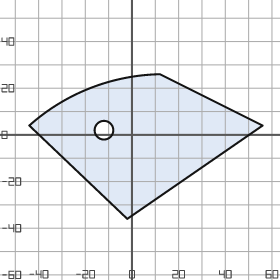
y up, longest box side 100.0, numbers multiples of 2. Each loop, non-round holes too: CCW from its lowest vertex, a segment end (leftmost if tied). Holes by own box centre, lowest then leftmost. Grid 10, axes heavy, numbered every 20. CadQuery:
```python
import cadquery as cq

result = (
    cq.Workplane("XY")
    .moveTo(-2.0, -36.0)
    .lineTo(56.0, 4.0)
    .lineTo(12.0, 26.0)
    .threePointArc((-18.0, 20.0), (-44.0, 4.0))
    .close()
    .moveTo(-12.0, 2.0)
    .circle(4.0)
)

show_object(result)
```